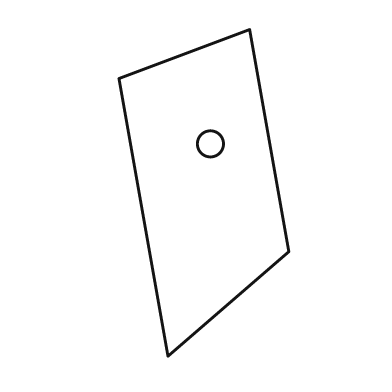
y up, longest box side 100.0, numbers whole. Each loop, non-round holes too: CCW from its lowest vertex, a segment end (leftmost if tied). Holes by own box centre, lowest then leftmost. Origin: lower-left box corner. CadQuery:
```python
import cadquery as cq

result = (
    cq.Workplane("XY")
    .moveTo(15.0, 0.0)
    .lineTo(52.0, 32.0)
    .lineTo(40.0, 100.0)
    .lineTo(0.0, 85.0)
    .close()
    .moveTo(28.0, 65.0)
    .circle(4.0)
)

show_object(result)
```